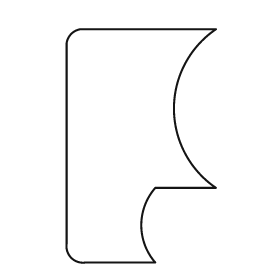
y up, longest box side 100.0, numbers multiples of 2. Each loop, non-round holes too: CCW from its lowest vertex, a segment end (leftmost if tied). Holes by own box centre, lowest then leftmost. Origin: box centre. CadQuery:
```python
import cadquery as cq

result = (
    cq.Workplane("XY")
    .moveTo(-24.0, -50.0)
    .lineTo(6.0, -50.0)
    .threePointArc((0.0, -34.0), (6.0, -18.0))
    .lineTo(32.0, -18.0)
    .threePointArc((14.0, 16.0), (32.0, 50.0))
    .lineTo(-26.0, 50.0)
    .threePointArc((-30.0, 48.0), (-32.0, 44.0))
    .lineTo(-32.0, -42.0)
    .threePointArc((-30.0, -48.0), (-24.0, -50.0))
    .close()
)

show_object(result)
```